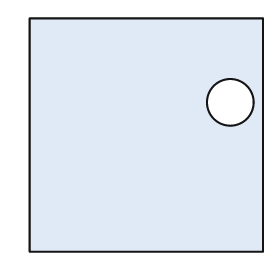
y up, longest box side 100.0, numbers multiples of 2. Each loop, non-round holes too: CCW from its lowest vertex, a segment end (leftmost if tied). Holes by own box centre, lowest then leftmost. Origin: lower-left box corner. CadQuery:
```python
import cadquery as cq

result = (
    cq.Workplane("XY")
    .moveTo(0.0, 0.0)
    .lineTo(100.0, 0.0)
    .lineTo(100.0, 100.0)
    .lineTo(0.0, 100.0)
    .close()
    .moveTo(86.0, 64.0)
    .circle(10.0)
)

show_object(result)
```